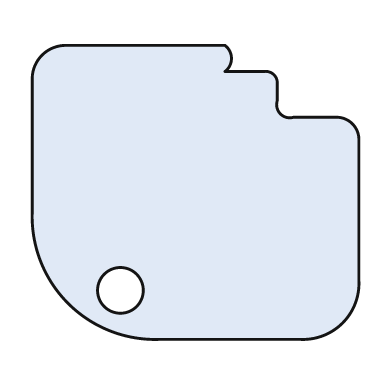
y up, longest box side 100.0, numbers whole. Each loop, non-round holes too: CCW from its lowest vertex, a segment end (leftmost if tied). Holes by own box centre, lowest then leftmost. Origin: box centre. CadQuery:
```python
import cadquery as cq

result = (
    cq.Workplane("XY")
    .moveTo(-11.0, -45.0)
    .lineTo(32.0, -45.0)
    .threePointArc((45.0, -40.0), (50.0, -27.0))
    .lineTo(50.0, 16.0)
    .threePointArc((48.0, 21.0), (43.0, 23.0))
    .lineTo(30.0, 23.0)
    .threePointArc((26.0, 24.0), (25.0, 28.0))
    .lineTo(25.0, 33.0)
    .threePointArc((24.0, 36.0), (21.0, 37.0))
    .lineTo(9.0, 37.0)
    .threePointArc((11.0, 41.0), (9.0, 45.0))
    .lineTo(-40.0, 45.0)
    .threePointArc((-47.0, 42.0), (-50.0, 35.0))
    .lineTo(-50.0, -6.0)
    .threePointArc((-39.0, -34.0), (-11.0, -45.0))
    .close()
    .moveTo(-23.0, -30.0)
    .circle(7.0)
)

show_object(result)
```